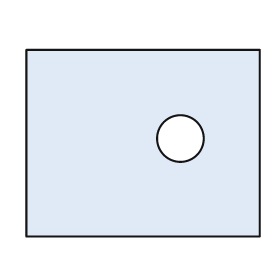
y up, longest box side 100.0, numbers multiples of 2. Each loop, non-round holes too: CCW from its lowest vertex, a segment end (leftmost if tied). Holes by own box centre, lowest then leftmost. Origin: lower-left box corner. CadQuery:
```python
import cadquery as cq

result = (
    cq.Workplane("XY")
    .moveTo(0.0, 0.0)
    .lineTo(100.0, 0.0)
    .lineTo(100.0, 80.0)
    .lineTo(0.0, 80.0)
    .close()
    .moveTo(66.0, 42.0)
    .circle(10.0)
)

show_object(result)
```